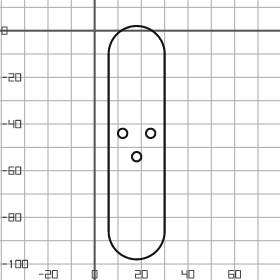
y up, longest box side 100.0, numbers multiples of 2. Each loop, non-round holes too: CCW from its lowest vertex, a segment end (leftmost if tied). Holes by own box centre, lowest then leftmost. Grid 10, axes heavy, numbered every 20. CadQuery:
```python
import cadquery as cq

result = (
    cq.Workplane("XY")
    .moveTo(6.0, -86.0)
    .threePointArc((18.0, -98.0), (30.0, -86.0))
    .lineTo(30.0, -10.0)
    .threePointArc((18.0, 2.0), (6.0, -10.0))
    .close()
    .moveTo(18.0, -54.0)
    .circle(2.0)
    .moveTo(12.0, -44.0)
    .circle(2.0)
    .moveTo(24.0, -44.0)
    .circle(2.0)
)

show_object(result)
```